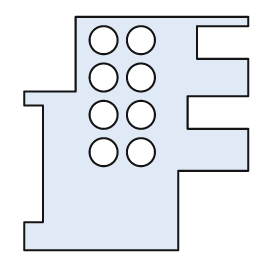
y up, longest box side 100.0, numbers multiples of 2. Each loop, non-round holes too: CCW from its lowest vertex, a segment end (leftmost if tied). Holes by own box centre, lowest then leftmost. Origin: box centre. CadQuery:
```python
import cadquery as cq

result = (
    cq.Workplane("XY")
    .moveTo(-48.0, -50.0)
    .lineTo(18.0, -50.0)
    .lineTo(18.0, -16.0)
    .lineTo(48.0, -16.0)
    .lineTo(48.0, 2.0)
    .lineTo(22.0, 2.0)
    .lineTo(22.0, 16.0)
    .lineTo(48.0, 16.0)
    .lineTo(48.0, 32.0)
    .lineTo(26.0, 32.0)
    .lineTo(26.0, 46.0)
    .lineTo(48.0, 46.0)
    .lineTo(48.0, 50.0)
    .lineTo(-26.0, 50.0)
    .lineTo(-26.0, 18.0)
    .lineTo(-48.0, 18.0)
    .lineTo(-48.0, 12.0)
    .lineTo(-40.0, 12.0)
    .lineTo(-40.0, -38.0)
    .lineTo(-48.0, -38.0)
    .close()
    .moveTo(-14.0, -8.0)
    .circle(6.0)
    .moveTo(2.0, -8.0)
    .circle(6.0)
    .moveTo(-14.0, 8.0)
    .circle(6.0)
    .moveTo(2.0, 8.0)
    .circle(6.0)
    .moveTo(-14.0, 24.0)
    .circle(6.0)
    .moveTo(2.0, 24.0)
    .circle(6.0)
    .moveTo(-14.0, 40.0)
    .circle(6.0)
    .moveTo(2.0, 40.0)
    .circle(6.0)
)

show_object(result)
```